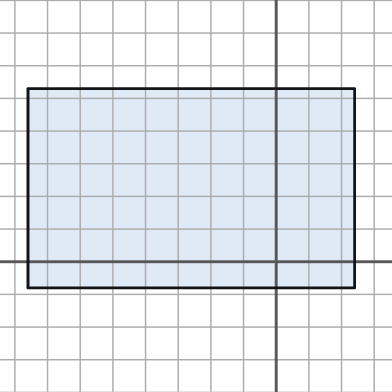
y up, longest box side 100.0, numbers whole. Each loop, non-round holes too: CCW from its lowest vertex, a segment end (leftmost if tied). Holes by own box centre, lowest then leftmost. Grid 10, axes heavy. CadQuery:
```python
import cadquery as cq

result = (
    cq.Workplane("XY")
    .moveTo(-76.0, -8.0)
    .lineTo(24.0, -8.0)
    .lineTo(24.0, 53.0)
    .lineTo(-76.0, 53.0)
    .close()
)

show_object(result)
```